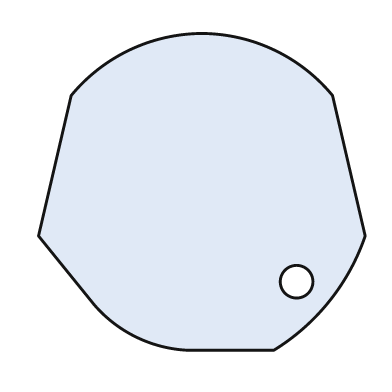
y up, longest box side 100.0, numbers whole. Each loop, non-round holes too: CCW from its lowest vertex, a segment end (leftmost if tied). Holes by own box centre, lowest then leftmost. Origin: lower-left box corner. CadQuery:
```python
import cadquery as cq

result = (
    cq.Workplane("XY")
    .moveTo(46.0, 0.0)
    .lineTo(72.0, 0.0)
    .threePointArc((89.0, 15.0), (100.0, 35.0))
    .lineTo(90.0, 78.0)
    .threePointArc((72.0, 92.0), (50.0, 97.0))
    .threePointArc((28.0, 92.0), (10.0, 78.0))
    .lineTo(0.0, 35.0)
    .lineTo(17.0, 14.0)
    .threePointArc((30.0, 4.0), (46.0, 0.0))
    .close()
    .moveTo(79.0, 21.0)
    .circle(5.0)
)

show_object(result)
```